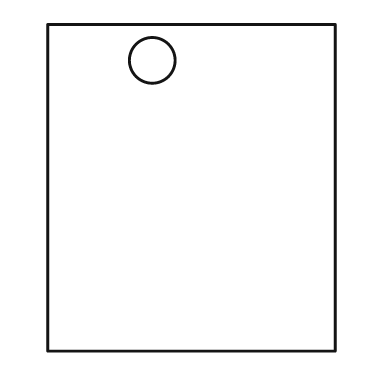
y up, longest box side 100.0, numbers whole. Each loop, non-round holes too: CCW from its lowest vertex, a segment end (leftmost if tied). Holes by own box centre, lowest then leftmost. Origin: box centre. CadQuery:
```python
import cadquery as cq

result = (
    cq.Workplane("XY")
    .moveTo(-44.0, -50.0)
    .lineTo(44.0, -50.0)
    .lineTo(44.0, 50.0)
    .lineTo(-44.0, 50.0)
    .close()
    .moveTo(-12.0, 39.0)
    .circle(7.0)
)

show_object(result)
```